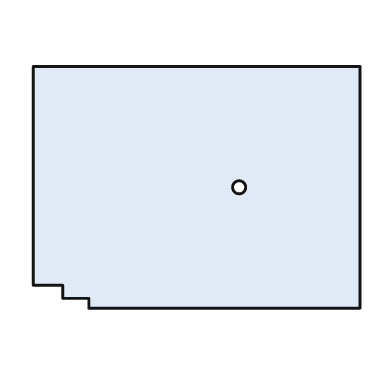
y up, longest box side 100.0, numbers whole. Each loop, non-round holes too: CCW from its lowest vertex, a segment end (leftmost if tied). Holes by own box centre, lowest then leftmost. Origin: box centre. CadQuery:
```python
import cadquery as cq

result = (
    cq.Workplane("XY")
    .moveTo(-33.0, -37.0)
    .lineTo(50.0, -37.0)
    .lineTo(50.0, 37.0)
    .lineTo(-50.0, 37.0)
    .lineTo(-50.0, -30.0)
    .lineTo(-41.0, -30.0)
    .lineTo(-41.0, -34.0)
    .lineTo(-33.0, -34.0)
    .close()
    .moveTo(13.0, 0.0)
    .circle(2.0)
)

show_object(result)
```